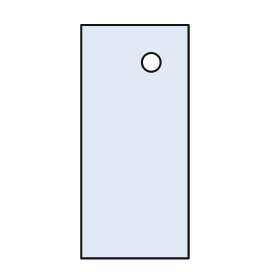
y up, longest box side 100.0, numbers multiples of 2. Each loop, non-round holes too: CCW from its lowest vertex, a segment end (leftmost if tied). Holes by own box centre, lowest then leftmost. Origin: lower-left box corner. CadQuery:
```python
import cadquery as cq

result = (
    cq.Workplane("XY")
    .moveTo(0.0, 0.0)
    .lineTo(46.0, 0.0)
    .lineTo(46.0, 100.0)
    .lineTo(0.0, 100.0)
    .close()
    .moveTo(30.0, 84.0)
    .circle(4.0)
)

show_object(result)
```